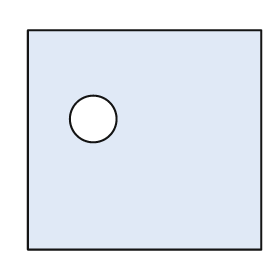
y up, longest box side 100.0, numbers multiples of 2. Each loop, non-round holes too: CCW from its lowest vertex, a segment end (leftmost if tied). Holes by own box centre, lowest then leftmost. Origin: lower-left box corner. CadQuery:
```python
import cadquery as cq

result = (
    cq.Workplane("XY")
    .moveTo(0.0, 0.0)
    .lineTo(100.0, 0.0)
    .lineTo(100.0, 94.0)
    .lineTo(0.0, 94.0)
    .close()
    .moveTo(28.0, 56.0)
    .circle(10.0)
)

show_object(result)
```